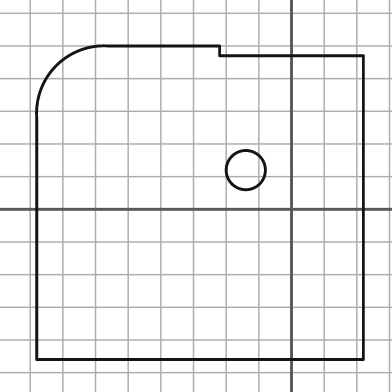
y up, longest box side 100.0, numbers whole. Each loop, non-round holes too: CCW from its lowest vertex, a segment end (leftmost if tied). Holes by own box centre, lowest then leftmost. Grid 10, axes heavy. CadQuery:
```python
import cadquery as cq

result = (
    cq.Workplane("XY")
    .moveTo(-78.0, -46.0)
    .lineTo(22.0, -46.0)
    .lineTo(22.0, 47.0)
    .lineTo(-22.0, 47.0)
    .lineTo(-22.0, 50.0)
    .lineTo(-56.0, 50.0)
    .threePointArc((-72.0, 44.0), (-78.0, 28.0))
    .close()
    .moveTo(-14.0, 12.0)
    .circle(6.0)
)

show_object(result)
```